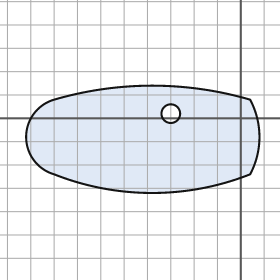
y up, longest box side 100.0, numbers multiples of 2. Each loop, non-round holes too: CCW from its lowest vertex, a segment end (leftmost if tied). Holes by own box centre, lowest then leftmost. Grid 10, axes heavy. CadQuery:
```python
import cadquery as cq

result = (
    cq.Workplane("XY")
    .moveTo(-80.0, -24.0)
    .threePointArc((-38.0, -32.0), (4.0, -24.0))
    .threePointArc((8.0, -8.0), (4.0, 8.0))
    .threePointArc((-38.0, 14.0), (-80.0, 8.0))
    .threePointArc((-92.0, -8.0), (-80.0, -24.0))
    .close()
    .moveTo(-30.0, 2.0)
    .circle(4.0)
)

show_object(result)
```